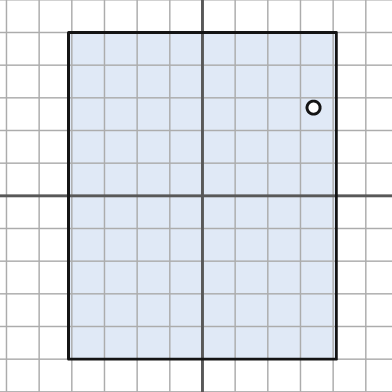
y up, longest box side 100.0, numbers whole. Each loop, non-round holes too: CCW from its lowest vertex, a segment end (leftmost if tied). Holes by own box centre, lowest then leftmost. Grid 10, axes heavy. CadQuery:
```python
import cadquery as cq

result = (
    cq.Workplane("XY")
    .moveTo(-41.0, -50.0)
    .lineTo(41.0, -50.0)
    .lineTo(41.0, 50.0)
    .lineTo(-41.0, 50.0)
    .close()
    .moveTo(34.0, 27.0)
    .circle(2.0)
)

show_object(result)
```